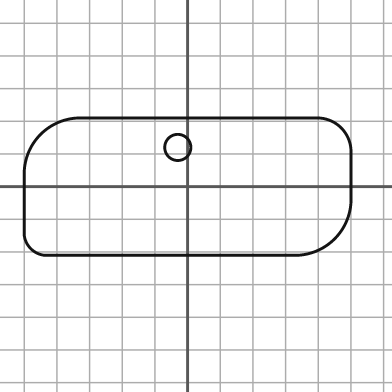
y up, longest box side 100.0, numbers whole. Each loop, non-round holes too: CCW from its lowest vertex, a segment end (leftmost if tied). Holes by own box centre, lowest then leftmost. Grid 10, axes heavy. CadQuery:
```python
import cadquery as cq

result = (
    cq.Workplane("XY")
    .moveTo(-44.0, -21.0)
    .lineTo(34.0, -21.0)
    .threePointArc((45.0, -16.0), (50.0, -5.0))
    .lineTo(50.0, 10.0)
    .threePointArc((47.0, 18.0), (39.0, 21.0))
    .lineTo(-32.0, 21.0)
    .threePointArc((-45.0, 16.0), (-50.0, 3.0))
    .lineTo(-50.0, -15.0)
    .threePointArc((-48.0, -19.0), (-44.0, -21.0))
    .close()
    .moveTo(-3.0, 12.0)
    .circle(4.0)
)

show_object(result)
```